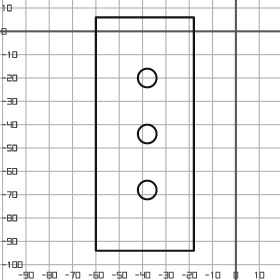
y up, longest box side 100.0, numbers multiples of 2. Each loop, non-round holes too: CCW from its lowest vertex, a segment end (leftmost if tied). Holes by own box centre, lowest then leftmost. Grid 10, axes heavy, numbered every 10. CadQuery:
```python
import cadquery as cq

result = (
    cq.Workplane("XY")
    .moveTo(-60.0, -94.0)
    .lineTo(-18.0, -94.0)
    .lineTo(-18.0, 6.0)
    .lineTo(-60.0, 6.0)
    .close()
    .moveTo(-38.0, -68.0)
    .circle(4.0)
    .moveTo(-38.0, -44.0)
    .circle(4.0)
    .moveTo(-38.0, -20.0)
    .circle(4.0)
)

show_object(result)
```